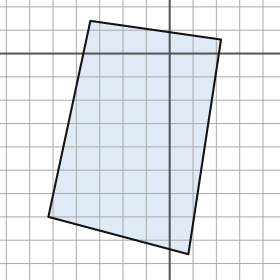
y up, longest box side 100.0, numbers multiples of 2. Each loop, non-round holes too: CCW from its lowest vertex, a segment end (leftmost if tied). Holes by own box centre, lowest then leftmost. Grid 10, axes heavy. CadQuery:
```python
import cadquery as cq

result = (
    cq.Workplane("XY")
    .moveTo(8.0, -86.0)
    .lineTo(22.0, 6.0)
    .lineTo(-34.0, 14.0)
    .lineTo(-52.0, -70.0)
    .close()
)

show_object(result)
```